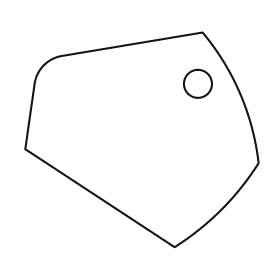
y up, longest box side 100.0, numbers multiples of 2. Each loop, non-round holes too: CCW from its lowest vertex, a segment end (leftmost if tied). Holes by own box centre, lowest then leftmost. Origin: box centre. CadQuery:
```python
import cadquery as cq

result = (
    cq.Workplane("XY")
    .moveTo(14.0, -46.0)
    .threePointArc((34.0, -30.0), (50.0, -10.0))
    .threePointArc((42.0, 20.0), (26.0, 46.0))
    .lineTo(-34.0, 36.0)
    .threePointArc((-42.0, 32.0), (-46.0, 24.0))
    .lineTo(-50.0, -4.0)
    .close()
    .moveTo(24.0, 24.0)
    .circle(6.0)
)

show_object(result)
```